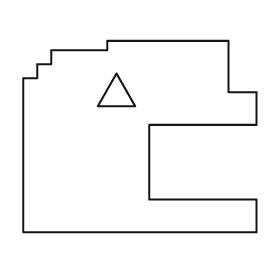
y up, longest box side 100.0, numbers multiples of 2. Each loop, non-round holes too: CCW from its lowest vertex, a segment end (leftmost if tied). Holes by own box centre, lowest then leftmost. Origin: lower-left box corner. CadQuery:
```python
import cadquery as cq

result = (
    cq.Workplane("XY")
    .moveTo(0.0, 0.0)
    .lineTo(100.0, 0.0)
    .lineTo(100.0, 14.0)
    .lineTo(54.0, 14.0)
    .lineTo(54.0, 46.0)
    .lineTo(100.0, 46.0)
    .lineTo(100.0, 60.0)
    .lineTo(88.0, 60.0)
    .lineTo(88.0, 82.0)
    .lineTo(36.0, 82.0)
    .lineTo(36.0, 78.0)
    .lineTo(12.0, 78.0)
    .lineTo(12.0, 72.0)
    .lineTo(6.0, 72.0)
    .lineTo(6.0, 66.0)
    .lineTo(0.0, 66.0)
    .close()
    .moveTo(32.0, 54.0)
    .lineTo(48.0, 54.0)
    .lineTo(40.0, 68.0)
    .close()
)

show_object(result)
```